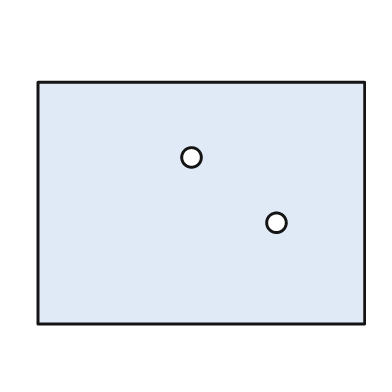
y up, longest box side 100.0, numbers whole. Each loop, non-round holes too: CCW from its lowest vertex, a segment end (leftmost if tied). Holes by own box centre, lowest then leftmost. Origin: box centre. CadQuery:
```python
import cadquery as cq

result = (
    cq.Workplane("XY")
    .moveTo(-50.0, -37.0)
    .lineTo(50.0, -37.0)
    .lineTo(50.0, 37.0)
    .lineTo(-50.0, 37.0)
    .close()
    .moveTo(23.0, -6.0)
    .circle(3.0)
    .moveTo(-3.0, 14.0)
    .circle(3.0)
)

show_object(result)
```